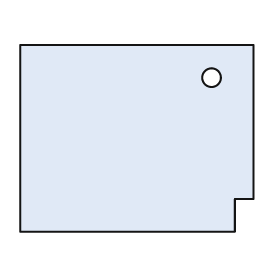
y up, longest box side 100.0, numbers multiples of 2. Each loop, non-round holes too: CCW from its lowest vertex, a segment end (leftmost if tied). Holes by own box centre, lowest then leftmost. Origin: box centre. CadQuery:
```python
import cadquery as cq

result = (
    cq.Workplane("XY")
    .moveTo(-50.0, -40.0)
    .lineTo(42.0, -40.0)
    .lineTo(42.0, -26.0)
    .lineTo(50.0, -26.0)
    .lineTo(50.0, 40.0)
    .lineTo(-50.0, 40.0)
    .close()
    .moveTo(32.0, 26.0)
    .circle(4.0)
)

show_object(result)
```